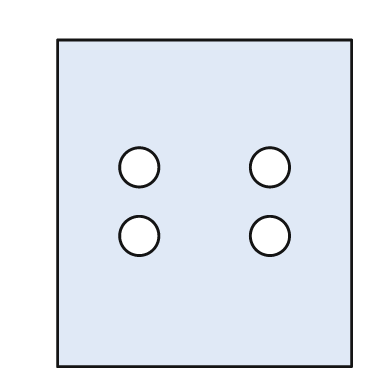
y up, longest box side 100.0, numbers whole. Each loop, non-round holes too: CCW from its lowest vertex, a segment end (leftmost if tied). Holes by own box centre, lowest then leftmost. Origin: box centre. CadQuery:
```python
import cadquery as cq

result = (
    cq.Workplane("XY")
    .moveTo(-45.0, -50.0)
    .lineTo(45.0, -50.0)
    .lineTo(45.0, 50.0)
    .lineTo(-45.0, 50.0)
    .close()
    .moveTo(-20.0, -10.0)
    .circle(6.0)
    .moveTo(20.0, -10.0)
    .circle(6.0)
    .moveTo(-20.0, 11.0)
    .circle(6.0)
    .moveTo(20.0, 11.0)
    .circle(6.0)
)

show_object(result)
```